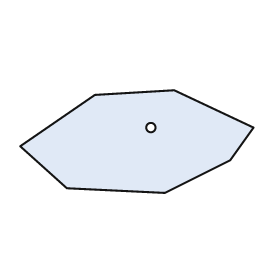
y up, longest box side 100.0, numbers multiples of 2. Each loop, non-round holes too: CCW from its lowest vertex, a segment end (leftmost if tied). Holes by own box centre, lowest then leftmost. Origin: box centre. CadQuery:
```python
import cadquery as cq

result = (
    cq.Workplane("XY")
    .moveTo(12.0, -22.0)
    .lineTo(40.0, -8.0)
    .lineTo(50.0, 6.0)
    .lineTo(16.0, 22.0)
    .lineTo(-18.0, 20.0)
    .lineTo(-50.0, -2.0)
    .lineTo(-30.0, -20.0)
    .close()
    .moveTo(6.0, 6.0)
    .circle(2.0)
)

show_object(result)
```